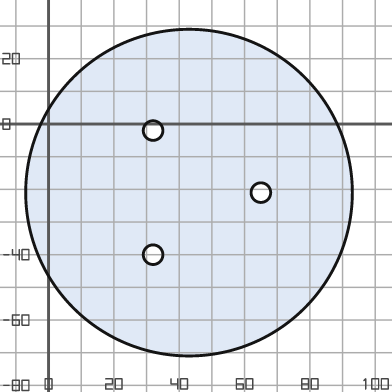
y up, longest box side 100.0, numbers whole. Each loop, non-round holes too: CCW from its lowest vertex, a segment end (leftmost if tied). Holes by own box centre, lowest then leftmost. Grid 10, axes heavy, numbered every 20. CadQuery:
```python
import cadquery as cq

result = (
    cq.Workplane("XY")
    .moveTo(43.0, -21.0)
    .circle(50.0)
    .moveTo(32.0, -40.0)
    .circle(3.0)
    .moveTo(65.0, -21.0)
    .circle(3.0)
    .moveTo(32.0, -2.0)
    .circle(3.0)
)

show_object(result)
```